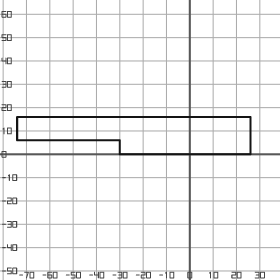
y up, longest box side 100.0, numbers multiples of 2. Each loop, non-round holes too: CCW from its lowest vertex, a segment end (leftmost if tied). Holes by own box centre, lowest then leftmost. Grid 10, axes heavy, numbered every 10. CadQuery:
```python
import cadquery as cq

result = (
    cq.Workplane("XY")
    .moveTo(-30.0, 0.0)
    .lineTo(26.0, 0.0)
    .lineTo(26.0, 16.0)
    .lineTo(-74.0, 16.0)
    .lineTo(-74.0, 6.0)
    .lineTo(-30.0, 6.0)
    .close()
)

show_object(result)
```